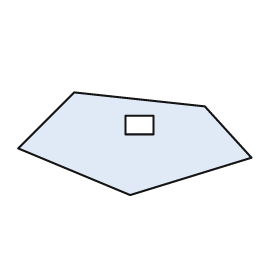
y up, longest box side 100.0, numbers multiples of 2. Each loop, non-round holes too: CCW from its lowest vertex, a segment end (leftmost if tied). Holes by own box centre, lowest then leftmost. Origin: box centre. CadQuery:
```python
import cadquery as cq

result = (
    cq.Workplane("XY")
    .moveTo(-2.0, -22.0)
    .lineTo(50.0, -6.0)
    .lineTo(30.0, 16.0)
    .lineTo(-26.0, 22.0)
    .lineTo(-50.0, -2.0)
    .close()
    .moveTo(-4.0, 4.0)
    .lineTo(8.0, 4.0)
    .lineTo(8.0, 12.0)
    .lineTo(-4.0, 12.0)
    .close()
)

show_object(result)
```